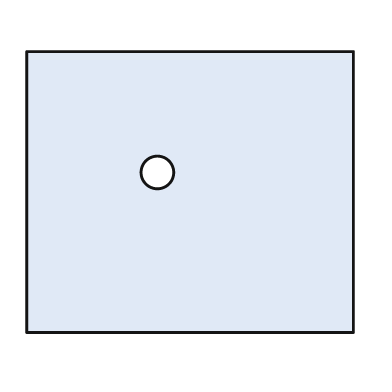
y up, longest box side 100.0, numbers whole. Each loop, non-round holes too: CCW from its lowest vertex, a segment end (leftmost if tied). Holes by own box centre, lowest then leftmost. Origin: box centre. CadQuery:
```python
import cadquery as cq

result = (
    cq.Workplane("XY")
    .moveTo(-50.0, -43.0)
    .lineTo(50.0, -43.0)
    .lineTo(50.0, 43.0)
    .lineTo(-50.0, 43.0)
    .close()
    .moveTo(-10.0, 6.0)
    .circle(5.0)
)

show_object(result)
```